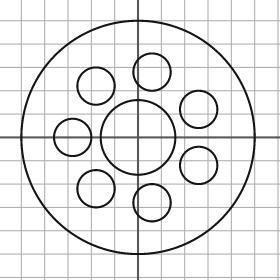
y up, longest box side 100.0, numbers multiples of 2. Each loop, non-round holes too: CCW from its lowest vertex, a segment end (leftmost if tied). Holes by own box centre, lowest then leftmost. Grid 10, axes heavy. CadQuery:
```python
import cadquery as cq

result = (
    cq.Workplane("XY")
    .moveTo(0.0, 0.0)
    .circle(50.0)
    .moveTo(6.0, -28.0)
    .circle(8.0)
    .moveTo(-18.0, -22.0)
    .circle(8.0)
    .moveTo(26.0, -12.0)
    .circle(8.0)
    .moveTo(-28.0, 0.0)
    .circle(8.0)
    .moveTo(0.0, 0.0)
    .circle(16.0)
    .moveTo(26.0, 12.0)
    .circle(8.0)
    .moveTo(-18.0, 22.0)
    .circle(8.0)
    .moveTo(6.0, 28.0)
    .circle(8.0)
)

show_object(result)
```